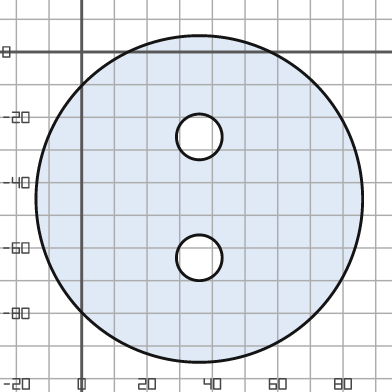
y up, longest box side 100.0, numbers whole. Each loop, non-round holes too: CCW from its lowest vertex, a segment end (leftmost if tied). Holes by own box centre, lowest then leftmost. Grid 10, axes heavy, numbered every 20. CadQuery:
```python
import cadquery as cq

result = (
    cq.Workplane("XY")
    .moveTo(36.0, -45.0)
    .circle(50.0)
    .moveTo(36.0, -63.0)
    .circle(7.0)
    .moveTo(36.0, -26.0)
    .circle(7.0)
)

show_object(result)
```